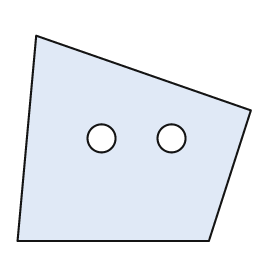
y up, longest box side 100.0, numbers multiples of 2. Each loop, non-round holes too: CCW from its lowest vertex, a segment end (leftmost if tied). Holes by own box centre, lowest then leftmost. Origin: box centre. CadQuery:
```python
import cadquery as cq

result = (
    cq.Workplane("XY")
    .moveTo(-50.0, -44.0)
    .lineTo(32.0, -44.0)
    .lineTo(50.0, 12.0)
    .lineTo(-42.0, 44.0)
    .close()
    .moveTo(-14.0, 0.0)
    .circle(6.0)
    .moveTo(16.0, 0.0)
    .circle(6.0)
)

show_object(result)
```